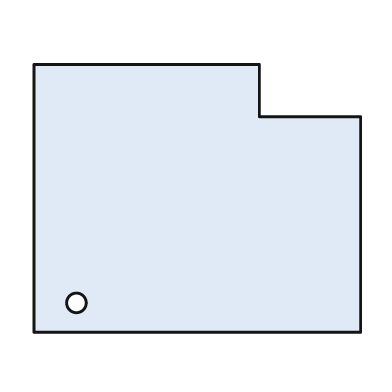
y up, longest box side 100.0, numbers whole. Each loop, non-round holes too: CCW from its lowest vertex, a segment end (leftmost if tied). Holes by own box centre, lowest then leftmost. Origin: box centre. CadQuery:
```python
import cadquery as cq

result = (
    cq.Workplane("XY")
    .moveTo(-50.0, -41.0)
    .lineTo(50.0, -41.0)
    .lineTo(50.0, 25.0)
    .lineTo(19.0, 25.0)
    .lineTo(19.0, 41.0)
    .lineTo(-50.0, 41.0)
    .close()
    .moveTo(-37.0, -32.0)
    .circle(3.0)
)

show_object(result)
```